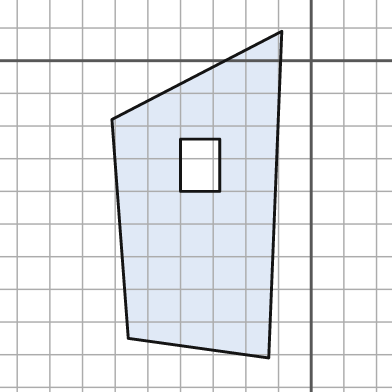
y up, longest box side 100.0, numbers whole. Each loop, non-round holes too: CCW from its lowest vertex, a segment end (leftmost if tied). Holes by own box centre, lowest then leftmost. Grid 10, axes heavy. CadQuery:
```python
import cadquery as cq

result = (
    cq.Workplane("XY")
    .moveTo(-13.0, -91.0)
    .lineTo(-9.0, 9.0)
    .lineTo(-61.0, -18.0)
    .lineTo(-56.0, -85.0)
    .close()
    .moveTo(-40.0, -40.0)
    .lineTo(-28.0, -40.0)
    .lineTo(-28.0, -24.0)
    .lineTo(-40.0, -24.0)
    .close()
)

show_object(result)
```